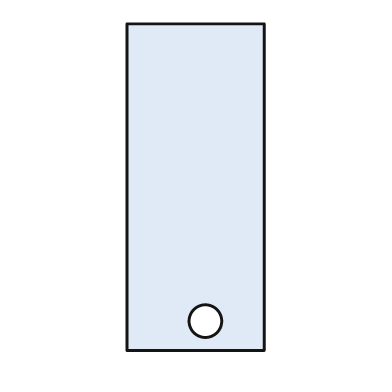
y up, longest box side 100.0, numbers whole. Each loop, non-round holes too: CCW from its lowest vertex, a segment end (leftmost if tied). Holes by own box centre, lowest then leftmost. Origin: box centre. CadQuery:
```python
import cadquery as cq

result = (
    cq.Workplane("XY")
    .moveTo(-21.0, -50.0)
    .lineTo(21.0, -50.0)
    .lineTo(21.0, 50.0)
    .lineTo(-21.0, 50.0)
    .close()
    .moveTo(3.0, -41.0)
    .circle(5.0)
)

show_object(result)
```